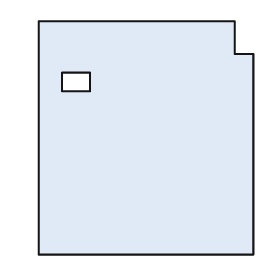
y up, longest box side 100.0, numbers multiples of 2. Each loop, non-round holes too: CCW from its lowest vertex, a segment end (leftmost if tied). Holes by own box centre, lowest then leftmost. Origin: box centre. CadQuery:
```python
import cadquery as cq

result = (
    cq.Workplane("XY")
    .moveTo(-46.0, -50.0)
    .lineTo(46.0, -50.0)
    .lineTo(46.0, 36.0)
    .lineTo(38.0, 36.0)
    .lineTo(38.0, 50.0)
    .lineTo(-46.0, 50.0)
    .close()
    .moveTo(-36.0, 20.0)
    .lineTo(-24.0, 20.0)
    .lineTo(-24.0, 28.0)
    .lineTo(-36.0, 28.0)
    .close()
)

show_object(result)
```